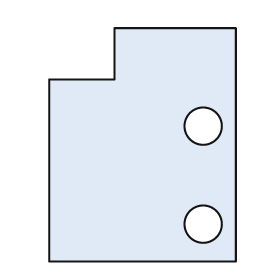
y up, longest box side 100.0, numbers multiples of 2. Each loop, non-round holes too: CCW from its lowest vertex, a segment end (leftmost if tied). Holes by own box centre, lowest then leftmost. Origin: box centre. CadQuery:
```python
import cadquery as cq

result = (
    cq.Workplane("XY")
    .moveTo(-40.0, -50.0)
    .lineTo(40.0, -50.0)
    .lineTo(40.0, 50.0)
    .lineTo(-12.0, 50.0)
    .lineTo(-12.0, 28.0)
    .lineTo(-40.0, 28.0)
    .close()
    .moveTo(26.0, -34.0)
    .circle(8.0)
    .moveTo(26.0, 8.0)
    .circle(8.0)
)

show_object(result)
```